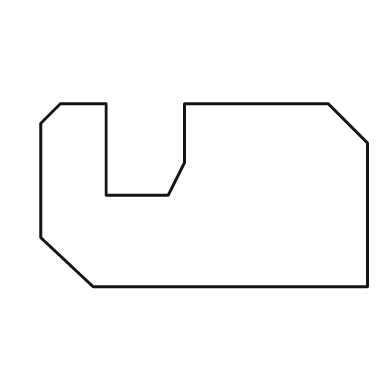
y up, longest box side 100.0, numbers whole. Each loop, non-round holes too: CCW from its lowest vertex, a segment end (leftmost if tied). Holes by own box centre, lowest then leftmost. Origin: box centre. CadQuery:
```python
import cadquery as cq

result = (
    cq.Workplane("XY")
    .moveTo(-34.0, -28.0)
    .lineTo(50.0, -28.0)
    .lineTo(50.0, 16.0)
    .lineTo(38.0, 28.0)
    .lineTo(-6.0, 28.0)
    .lineTo(-6.0, 10.0)
    .lineTo(-11.0, 0.0)
    .lineTo(-30.0, 0.0)
    .lineTo(-30.0, 28.0)
    .lineTo(-44.0, 28.0)
    .lineTo(-50.0, 22.0)
    .lineTo(-50.0, -13.0)
    .close()
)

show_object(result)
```